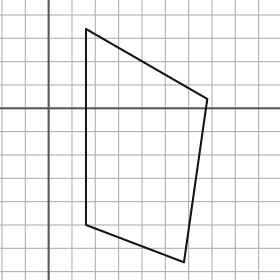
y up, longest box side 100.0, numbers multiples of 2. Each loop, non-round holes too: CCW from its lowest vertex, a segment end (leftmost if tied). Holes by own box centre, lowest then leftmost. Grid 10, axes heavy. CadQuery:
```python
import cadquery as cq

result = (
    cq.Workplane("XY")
    .moveTo(58.0, -66.0)
    .lineTo(68.0, 4.0)
    .lineTo(16.0, 34.0)
    .lineTo(16.0, -50.0)
    .close()
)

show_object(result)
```